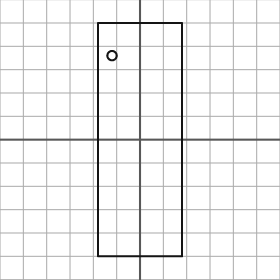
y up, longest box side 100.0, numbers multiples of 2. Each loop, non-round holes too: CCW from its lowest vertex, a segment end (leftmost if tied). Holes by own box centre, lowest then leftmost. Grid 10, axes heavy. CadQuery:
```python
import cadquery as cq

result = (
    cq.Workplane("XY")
    .moveTo(-18.0, -50.0)
    .lineTo(18.0, -50.0)
    .lineTo(18.0, 50.0)
    .lineTo(-18.0, 50.0)
    .close()
    .moveTo(-12.0, 36.0)
    .circle(2.0)
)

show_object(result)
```